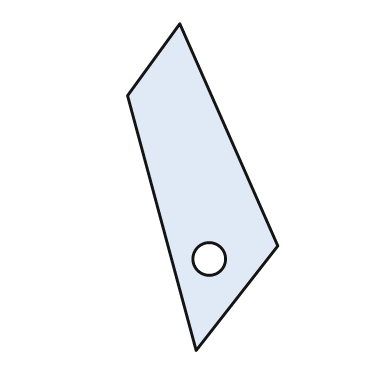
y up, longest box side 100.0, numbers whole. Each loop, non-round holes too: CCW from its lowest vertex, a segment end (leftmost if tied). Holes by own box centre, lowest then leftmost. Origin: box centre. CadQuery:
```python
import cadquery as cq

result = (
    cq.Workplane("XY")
    .moveTo(-2.0, -50.0)
    .lineTo(23.0, -18.0)
    .lineTo(-7.0, 50.0)
    .lineTo(-23.0, 28.0)
    .close()
    .moveTo(2.0, -22.0)
    .circle(5.0)
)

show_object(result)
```